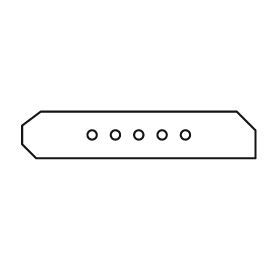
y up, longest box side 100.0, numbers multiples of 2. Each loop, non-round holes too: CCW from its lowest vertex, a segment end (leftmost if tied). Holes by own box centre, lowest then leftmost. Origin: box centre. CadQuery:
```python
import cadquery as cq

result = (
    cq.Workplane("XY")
    .moveTo(-44.0, -10.0)
    .lineTo(50.0, -10.0)
    .lineTo(50.0, 2.0)
    .lineTo(42.0, 10.0)
    .lineTo(-42.0, 10.0)
    .lineTo(-50.0, 4.0)
    .lineTo(-50.0, -4.0)
    .close()
    .moveTo(-20.0, 0.0)
    .circle(2.0)
    .moveTo(-10.0, 0.0)
    .circle(2.0)
    .moveTo(0.0, 0.0)
    .circle(2.0)
    .moveTo(10.0, 0.0)
    .circle(2.0)
    .moveTo(20.0, 0.0)
    .circle(2.0)
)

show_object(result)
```